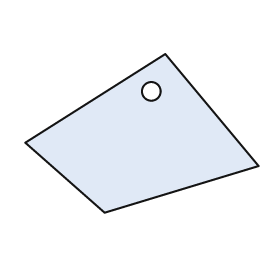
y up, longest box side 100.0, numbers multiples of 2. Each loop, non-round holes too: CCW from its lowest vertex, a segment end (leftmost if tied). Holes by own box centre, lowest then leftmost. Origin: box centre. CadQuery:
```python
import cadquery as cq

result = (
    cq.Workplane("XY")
    .moveTo(-16.0, -34.0)
    .lineTo(50.0, -14.0)
    .lineTo(10.0, 34.0)
    .lineTo(-50.0, -4.0)
    .close()
    .moveTo(4.0, 18.0)
    .circle(4.0)
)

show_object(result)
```